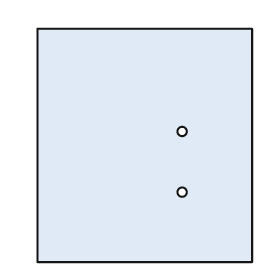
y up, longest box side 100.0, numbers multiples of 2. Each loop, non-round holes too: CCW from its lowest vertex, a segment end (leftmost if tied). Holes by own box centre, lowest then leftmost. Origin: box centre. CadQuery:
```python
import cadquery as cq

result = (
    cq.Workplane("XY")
    .moveTo(-46.0, -50.0)
    .lineTo(46.0, -50.0)
    .lineTo(46.0, 50.0)
    .lineTo(-46.0, 50.0)
    .close()
    .moveTo(16.0, -20.0)
    .circle(2.0)
    .moveTo(16.0, 6.0)
    .circle(2.0)
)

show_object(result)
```